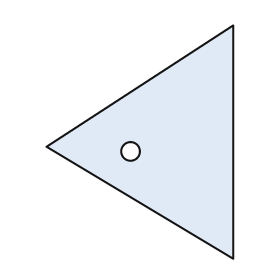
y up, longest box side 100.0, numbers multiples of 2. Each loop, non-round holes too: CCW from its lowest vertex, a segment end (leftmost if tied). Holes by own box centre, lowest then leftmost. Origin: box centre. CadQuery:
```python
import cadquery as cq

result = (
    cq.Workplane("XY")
    .moveTo(40.0, -50.0)
    .lineTo(40.0, 50.0)
    .lineTo(-40.0, -2.0)
    .close()
    .moveTo(-4.0, -4.0)
    .circle(4.0)
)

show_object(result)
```